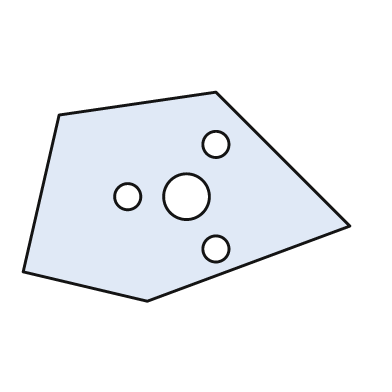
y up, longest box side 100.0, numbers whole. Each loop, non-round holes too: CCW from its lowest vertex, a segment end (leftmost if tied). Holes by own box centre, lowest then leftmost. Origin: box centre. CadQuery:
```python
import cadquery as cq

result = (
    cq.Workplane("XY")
    .moveTo(-12.0, -32.0)
    .lineTo(50.0, -9.0)
    .lineTo(9.0, 32.0)
    .lineTo(-39.0, 25.0)
    .lineTo(-50.0, -23.0)
    .close()
    .moveTo(9.0, -16.0)
    .circle(4.0)
    .moveTo(-18.0, 0.0)
    .circle(4.0)
    .moveTo(0.0, 0.0)
    .circle(7.0)
    .moveTo(9.0, 16.0)
    .circle(4.0)
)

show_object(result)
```